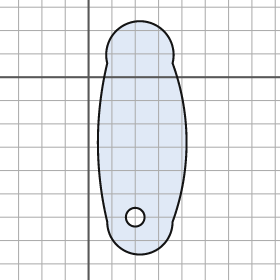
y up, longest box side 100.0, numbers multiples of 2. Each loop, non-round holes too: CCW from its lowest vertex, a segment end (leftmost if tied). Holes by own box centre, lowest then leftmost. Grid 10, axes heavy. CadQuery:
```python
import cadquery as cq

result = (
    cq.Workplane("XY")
    .moveTo(8.0, -62.0)
    .threePointArc((22.0, -76.0), (36.0, -62.0))
    .threePointArc((42.0, -28.0), (36.0, 6.0))
    .threePointArc((22.0, 24.0), (8.0, 6.0))
    .threePointArc((4.0, -28.0), (8.0, -62.0))
    .close()
    .moveTo(20.0, -60.0)
    .circle(4.0)
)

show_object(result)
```